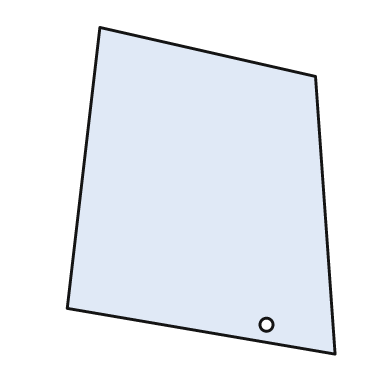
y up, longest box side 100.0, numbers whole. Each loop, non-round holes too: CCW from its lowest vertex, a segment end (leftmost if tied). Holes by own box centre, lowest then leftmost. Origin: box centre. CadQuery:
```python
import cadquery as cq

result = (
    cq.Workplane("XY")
    .moveTo(41.0, -50.0)
    .lineTo(35.0, 35.0)
    .lineTo(-31.0, 50.0)
    .lineTo(-41.0, -36.0)
    .close()
    .moveTo(20.0, -41.0)
    .circle(2.0)
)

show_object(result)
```